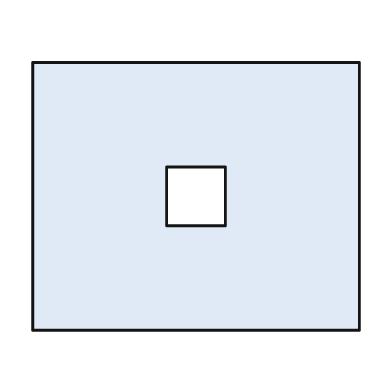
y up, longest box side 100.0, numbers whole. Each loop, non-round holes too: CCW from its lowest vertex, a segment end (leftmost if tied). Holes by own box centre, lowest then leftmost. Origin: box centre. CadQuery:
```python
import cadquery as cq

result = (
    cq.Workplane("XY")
    .moveTo(-50.0, -41.0)
    .lineTo(50.0, -41.0)
    .lineTo(50.0, 41.0)
    .lineTo(-50.0, 41.0)
    .close()
    .moveTo(-9.0, -9.0)
    .lineTo(9.0, -9.0)
    .lineTo(9.0, 9.0)
    .lineTo(-9.0, 9.0)
    .close()
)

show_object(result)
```